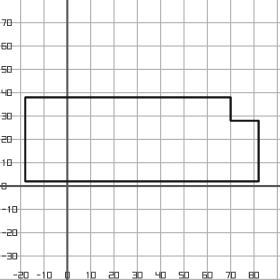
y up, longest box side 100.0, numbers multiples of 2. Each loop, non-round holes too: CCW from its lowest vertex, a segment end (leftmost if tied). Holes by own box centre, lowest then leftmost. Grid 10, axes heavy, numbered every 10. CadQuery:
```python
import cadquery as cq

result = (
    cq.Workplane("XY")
    .moveTo(-18.0, 2.0)
    .lineTo(82.0, 2.0)
    .lineTo(82.0, 28.0)
    .lineTo(70.0, 28.0)
    .lineTo(70.0, 38.0)
    .lineTo(-18.0, 38.0)
    .close()
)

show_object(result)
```